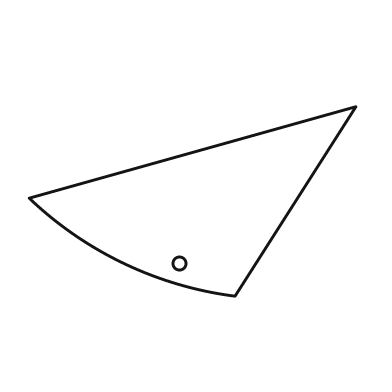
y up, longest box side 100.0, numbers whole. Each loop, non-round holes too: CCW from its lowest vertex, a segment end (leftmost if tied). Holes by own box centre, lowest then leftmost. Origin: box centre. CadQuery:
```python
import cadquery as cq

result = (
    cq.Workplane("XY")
    .moveTo(13.0, -29.0)
    .lineTo(50.0, 29.0)
    .lineTo(-50.0, 1.0)
    .threePointArc((-21.0, -19.0), (13.0, -29.0))
    .close()
    .moveTo(-4.0, -19.0)
    .circle(2.0)
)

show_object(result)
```